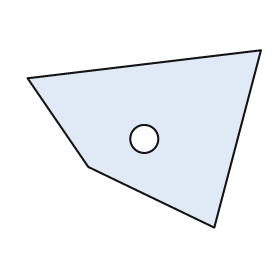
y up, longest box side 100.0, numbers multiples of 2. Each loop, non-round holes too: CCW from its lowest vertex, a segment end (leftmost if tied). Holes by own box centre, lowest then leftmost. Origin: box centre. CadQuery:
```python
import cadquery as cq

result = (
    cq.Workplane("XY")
    .moveTo(30.0, -38.0)
    .lineTo(50.0, 38.0)
    .lineTo(-50.0, 26.0)
    .lineTo(-24.0, -12.0)
    .close()
    .moveTo(0.0, 0.0)
    .circle(6.0)
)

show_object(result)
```